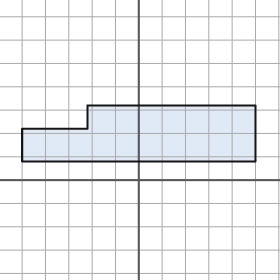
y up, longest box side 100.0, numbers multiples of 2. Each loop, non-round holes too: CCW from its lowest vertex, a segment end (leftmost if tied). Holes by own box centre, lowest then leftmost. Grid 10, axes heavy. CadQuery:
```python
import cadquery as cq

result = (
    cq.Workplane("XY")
    .moveTo(-50.0, 8.0)
    .lineTo(50.0, 8.0)
    .lineTo(50.0, 32.0)
    .lineTo(-22.0, 32.0)
    .lineTo(-22.0, 22.0)
    .lineTo(-50.0, 22.0)
    .close()
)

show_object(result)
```